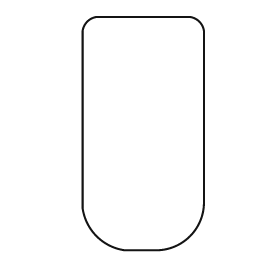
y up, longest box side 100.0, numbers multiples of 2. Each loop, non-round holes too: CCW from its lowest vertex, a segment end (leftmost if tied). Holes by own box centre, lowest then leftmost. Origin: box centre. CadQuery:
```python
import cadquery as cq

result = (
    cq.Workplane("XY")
    .moveTo(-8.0, -50.0)
    .lineTo(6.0, -50.0)
    .threePointArc((20.0, -44.0), (26.0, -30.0))
    .lineTo(26.0, 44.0)
    .threePointArc((24.0, 48.0), (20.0, 50.0))
    .lineTo(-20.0, 50.0)
    .threePointArc((-24.0, 48.0), (-26.0, 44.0))
    .lineTo(-26.0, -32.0)
    .threePointArc((-20.0, -44.0), (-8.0, -50.0))
    .close()
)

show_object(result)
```